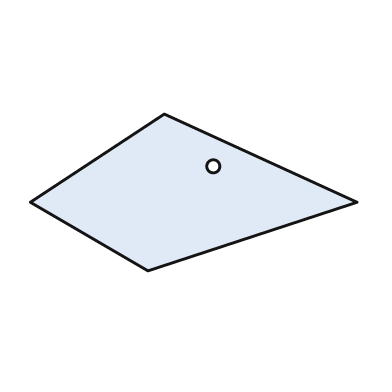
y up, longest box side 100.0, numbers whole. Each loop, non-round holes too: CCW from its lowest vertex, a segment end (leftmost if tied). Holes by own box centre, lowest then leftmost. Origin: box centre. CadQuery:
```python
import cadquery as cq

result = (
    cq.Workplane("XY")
    .moveTo(-14.0, -24.0)
    .lineTo(50.0, -3.0)
    .lineTo(-9.0, 24.0)
    .lineTo(-50.0, -3.0)
    .close()
    .moveTo(6.0, 8.0)
    .circle(2.0)
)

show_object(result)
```